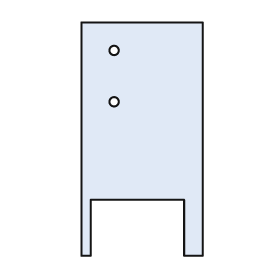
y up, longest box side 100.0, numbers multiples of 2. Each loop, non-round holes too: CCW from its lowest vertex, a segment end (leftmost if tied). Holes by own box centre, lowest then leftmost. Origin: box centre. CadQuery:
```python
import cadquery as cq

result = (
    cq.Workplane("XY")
    .moveTo(-26.0, -50.0)
    .lineTo(-22.0, -50.0)
    .lineTo(-22.0, -26.0)
    .lineTo(18.0, -26.0)
    .lineTo(18.0, -50.0)
    .lineTo(26.0, -50.0)
    .lineTo(26.0, 50.0)
    .lineTo(-26.0, 50.0)
    .close()
    .moveTo(-12.0, 16.0)
    .circle(2.0)
    .moveTo(-12.0, 38.0)
    .circle(2.0)
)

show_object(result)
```